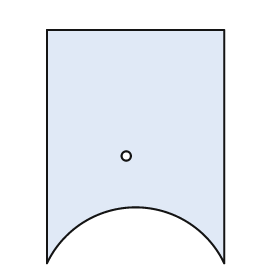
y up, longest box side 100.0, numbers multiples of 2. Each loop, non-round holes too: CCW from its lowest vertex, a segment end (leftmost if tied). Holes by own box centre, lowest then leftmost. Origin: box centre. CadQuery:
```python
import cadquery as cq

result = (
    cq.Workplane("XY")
    .moveTo(-38.0, -50.0)
    .threePointArc((0.0, -26.0), (38.0, -50.0))
    .lineTo(38.0, 50.0)
    .lineTo(-38.0, 50.0)
    .close()
    .moveTo(-4.0, -4.0)
    .circle(2.0)
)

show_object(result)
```